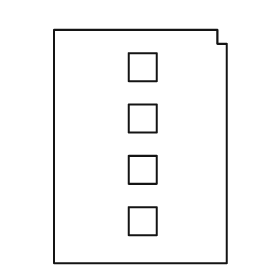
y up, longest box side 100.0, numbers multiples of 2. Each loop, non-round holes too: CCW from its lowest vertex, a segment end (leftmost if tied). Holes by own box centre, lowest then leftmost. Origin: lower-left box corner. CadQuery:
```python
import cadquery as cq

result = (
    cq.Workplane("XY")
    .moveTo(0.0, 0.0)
    .lineTo(74.0, 0.0)
    .lineTo(74.0, 94.0)
    .lineTo(70.0, 94.0)
    .lineTo(70.0, 100.0)
    .lineTo(0.0, 100.0)
    .close()
    .moveTo(32.0, 12.0)
    .lineTo(44.0, 12.0)
    .lineTo(44.0, 24.0)
    .lineTo(32.0, 24.0)
    .close()
    .moveTo(32.0, 34.0)
    .lineTo(44.0, 34.0)
    .lineTo(44.0, 46.0)
    .lineTo(32.0, 46.0)
    .close()
    .moveTo(32.0, 56.0)
    .lineTo(44.0, 56.0)
    .lineTo(44.0, 68.0)
    .lineTo(32.0, 68.0)
    .close()
    .moveTo(32.0, 78.0)
    .lineTo(44.0, 78.0)
    .lineTo(44.0, 90.0)
    .lineTo(32.0, 90.0)
    .close()
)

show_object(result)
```